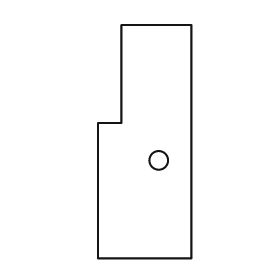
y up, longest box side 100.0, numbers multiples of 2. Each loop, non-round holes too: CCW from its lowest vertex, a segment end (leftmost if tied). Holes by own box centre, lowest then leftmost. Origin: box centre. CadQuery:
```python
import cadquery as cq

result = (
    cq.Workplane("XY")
    .moveTo(-20.0, -50.0)
    .lineTo(20.0, -50.0)
    .lineTo(20.0, 50.0)
    .lineTo(-10.0, 50.0)
    .lineTo(-10.0, 8.0)
    .lineTo(-20.0, 8.0)
    .close()
    .moveTo(6.0, -8.0)
    .circle(4.0)
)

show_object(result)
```